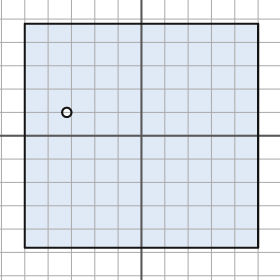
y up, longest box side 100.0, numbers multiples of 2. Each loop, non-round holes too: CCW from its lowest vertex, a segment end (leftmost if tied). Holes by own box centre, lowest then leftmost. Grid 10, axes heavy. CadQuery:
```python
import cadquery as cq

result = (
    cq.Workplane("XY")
    .moveTo(-50.0, -48.0)
    .lineTo(50.0, -48.0)
    .lineTo(50.0, 48.0)
    .lineTo(-50.0, 48.0)
    .close()
    .moveTo(-32.0, 10.0)
    .circle(2.0)
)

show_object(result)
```